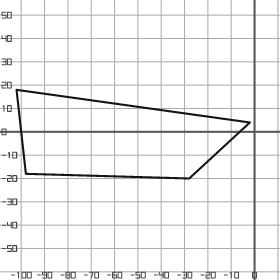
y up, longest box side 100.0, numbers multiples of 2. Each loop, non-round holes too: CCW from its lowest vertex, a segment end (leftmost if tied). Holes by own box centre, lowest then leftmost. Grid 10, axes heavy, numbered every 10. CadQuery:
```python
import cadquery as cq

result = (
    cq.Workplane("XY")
    .moveTo(-28.0, -20.0)
    .lineTo(-2.0, 4.0)
    .lineTo(-102.0, 18.0)
    .lineTo(-98.0, -18.0)
    .close()
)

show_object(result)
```